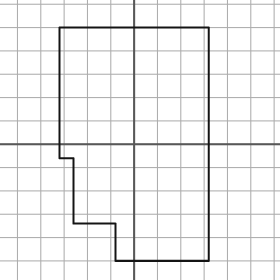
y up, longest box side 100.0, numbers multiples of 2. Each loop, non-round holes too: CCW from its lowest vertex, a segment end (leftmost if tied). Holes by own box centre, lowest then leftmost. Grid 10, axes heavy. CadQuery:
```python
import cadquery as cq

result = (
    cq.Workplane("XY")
    .moveTo(-8.0, -50.0)
    .lineTo(32.0, -50.0)
    .lineTo(32.0, 50.0)
    .lineTo(-32.0, 50.0)
    .lineTo(-32.0, -6.0)
    .lineTo(-26.0, -6.0)
    .lineTo(-26.0, -34.0)
    .lineTo(-8.0, -34.0)
    .close()
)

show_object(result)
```